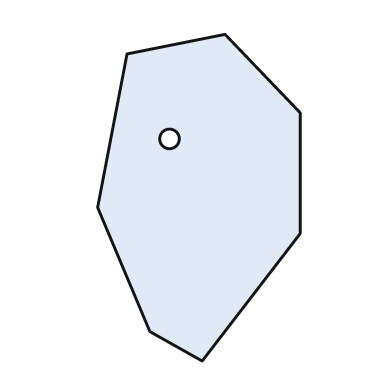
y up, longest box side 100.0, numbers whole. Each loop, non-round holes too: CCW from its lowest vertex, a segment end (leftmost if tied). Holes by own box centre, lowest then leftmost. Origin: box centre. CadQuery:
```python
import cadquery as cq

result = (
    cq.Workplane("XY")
    .moveTo(1.0, -50.0)
    .lineTo(31.0, -11.0)
    .lineTo(31.0, 26.0)
    .lineTo(8.0, 50.0)
    .lineTo(-22.0, 44.0)
    .lineTo(-31.0, -3.0)
    .lineTo(-15.0, -41.0)
    .close()
    .moveTo(-9.0, 18.0)
    .circle(3.0)
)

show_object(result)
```